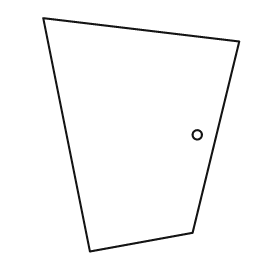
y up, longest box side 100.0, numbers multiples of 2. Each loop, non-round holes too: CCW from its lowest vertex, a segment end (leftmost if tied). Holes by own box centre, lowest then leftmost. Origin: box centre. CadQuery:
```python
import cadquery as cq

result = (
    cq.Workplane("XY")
    .moveTo(-22.0, -50.0)
    .lineTo(22.0, -42.0)
    .lineTo(42.0, 40.0)
    .lineTo(-42.0, 50.0)
    .close()
    .moveTo(24.0, 0.0)
    .circle(2.0)
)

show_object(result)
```